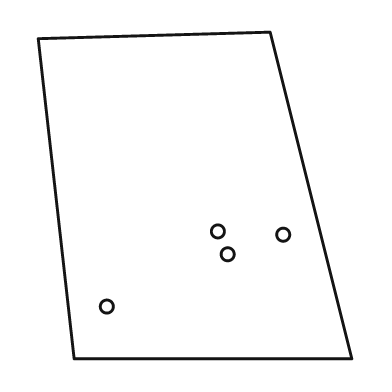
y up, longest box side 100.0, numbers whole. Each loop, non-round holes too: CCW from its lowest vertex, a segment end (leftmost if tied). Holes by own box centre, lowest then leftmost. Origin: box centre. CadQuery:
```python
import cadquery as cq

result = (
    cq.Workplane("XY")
    .moveTo(-37.0, -50.0)
    .lineTo(48.0, -50.0)
    .lineTo(23.0, 50.0)
    .lineTo(-48.0, 48.0)
    .close()
    .moveTo(-27.0, -34.0)
    .circle(2.0)
    .moveTo(10.0, -18.0)
    .circle(2.0)
    .moveTo(27.0, -12.0)
    .circle(2.0)
    .moveTo(7.0, -11.0)
    .circle(2.0)
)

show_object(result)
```